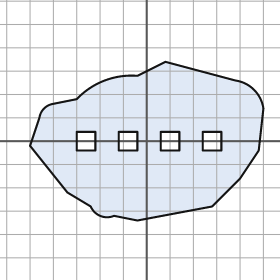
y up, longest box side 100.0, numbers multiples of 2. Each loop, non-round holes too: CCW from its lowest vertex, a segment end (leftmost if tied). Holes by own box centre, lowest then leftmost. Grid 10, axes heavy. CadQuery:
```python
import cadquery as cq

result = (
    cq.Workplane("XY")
    .moveTo(-4.0, -34.0)
    .lineTo(28.0, -28.0)
    .lineTo(40.0, -16.0)
    .lineTo(48.0, -4.0)
    .lineTo(50.0, 14.0)
    .threePointArc((46.0, 22.0), (38.0, 26.0))
    .lineTo(8.0, 34.0)
    .lineTo(-4.0, 28.0)
    .threePointArc((-18.0, 26.0), (-30.0, 18.0))
    .lineTo(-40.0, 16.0)
    .threePointArc((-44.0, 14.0), (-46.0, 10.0))
    .lineTo(-50.0, -2.0)
    .lineTo(-34.0, -22.0)
    .lineTo(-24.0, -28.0)
    .threePointArc((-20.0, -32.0), (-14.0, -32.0))
    .close()
    .moveTo(-30.0, -4.0)
    .lineTo(-22.0, -4.0)
    .lineTo(-22.0, 4.0)
    .lineTo(-30.0, 4.0)
    .close()
    .moveTo(-12.0, -4.0)
    .lineTo(-4.0, -4.0)
    .lineTo(-4.0, 4.0)
    .lineTo(-12.0, 4.0)
    .close()
    .moveTo(6.0, -4.0)
    .lineTo(14.0, -4.0)
    .lineTo(14.0, 4.0)
    .lineTo(6.0, 4.0)
    .close()
    .moveTo(24.0, -4.0)
    .lineTo(32.0, -4.0)
    .lineTo(32.0, 4.0)
    .lineTo(24.0, 4.0)
    .close()
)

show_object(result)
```